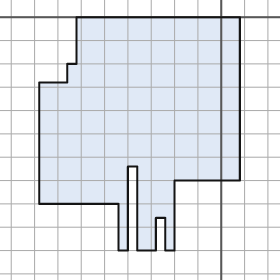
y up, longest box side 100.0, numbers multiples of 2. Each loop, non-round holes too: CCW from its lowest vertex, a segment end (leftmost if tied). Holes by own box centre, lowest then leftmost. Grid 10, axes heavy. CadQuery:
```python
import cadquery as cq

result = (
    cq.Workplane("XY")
    .moveTo(-44.0, -100.0)
    .lineTo(-40.0, -100.0)
    .lineTo(-40.0, -64.0)
    .lineTo(-36.0, -64.0)
    .lineTo(-36.0, -100.0)
    .lineTo(-28.0, -100.0)
    .lineTo(-28.0, -86.0)
    .lineTo(-24.0, -86.0)
    .lineTo(-24.0, -100.0)
    .lineTo(-20.0, -100.0)
    .lineTo(-20.0, -70.0)
    .lineTo(8.0, -70.0)
    .lineTo(8.0, 0.0)
    .lineTo(-62.0, 0.0)
    .lineTo(-62.0, -20.0)
    .lineTo(-66.0, -20.0)
    .lineTo(-66.0, -28.0)
    .lineTo(-78.0, -28.0)
    .lineTo(-78.0, -80.0)
    .lineTo(-44.0, -80.0)
    .close()
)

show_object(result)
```